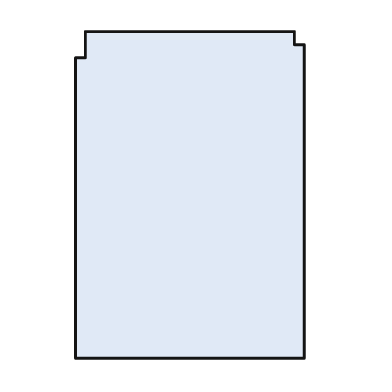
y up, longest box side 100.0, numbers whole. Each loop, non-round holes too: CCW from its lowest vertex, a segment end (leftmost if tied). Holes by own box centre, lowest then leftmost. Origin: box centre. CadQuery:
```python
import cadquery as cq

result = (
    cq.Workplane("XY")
    .moveTo(-35.0, -50.0)
    .lineTo(35.0, -50.0)
    .lineTo(35.0, 46.0)
    .lineTo(32.0, 46.0)
    .lineTo(32.0, 50.0)
    .lineTo(-32.0, 50.0)
    .lineTo(-32.0, 42.0)
    .lineTo(-35.0, 42.0)
    .close()
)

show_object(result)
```